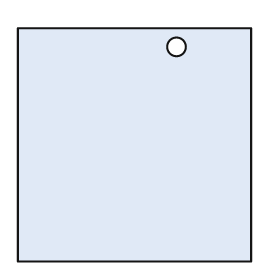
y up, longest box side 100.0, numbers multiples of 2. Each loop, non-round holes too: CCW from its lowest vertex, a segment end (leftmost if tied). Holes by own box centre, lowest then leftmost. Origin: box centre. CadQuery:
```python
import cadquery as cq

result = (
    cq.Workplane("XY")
    .moveTo(-50.0, -50.0)
    .lineTo(50.0, -50.0)
    .lineTo(50.0, 50.0)
    .lineTo(-50.0, 50.0)
    .close()
    .moveTo(18.0, 42.0)
    .circle(4.0)
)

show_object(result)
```